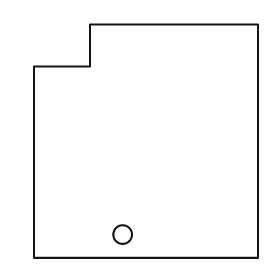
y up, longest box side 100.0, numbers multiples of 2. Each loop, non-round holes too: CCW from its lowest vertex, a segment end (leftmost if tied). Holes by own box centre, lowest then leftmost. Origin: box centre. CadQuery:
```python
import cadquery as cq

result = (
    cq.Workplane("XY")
    .moveTo(-48.0, -50.0)
    .lineTo(48.0, -50.0)
    .lineTo(48.0, 50.0)
    .lineTo(-24.0, 50.0)
    .lineTo(-24.0, 32.0)
    .lineTo(-48.0, 32.0)
    .close()
    .moveTo(-10.0, -40.0)
    .circle(4.0)
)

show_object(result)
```